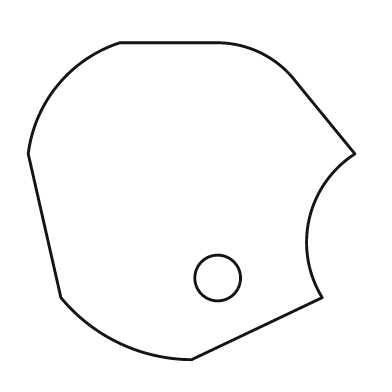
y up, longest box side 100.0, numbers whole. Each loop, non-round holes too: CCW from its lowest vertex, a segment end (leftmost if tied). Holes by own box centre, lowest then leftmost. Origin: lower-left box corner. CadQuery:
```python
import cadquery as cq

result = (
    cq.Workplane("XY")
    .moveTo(50.0, 0.0)
    .lineTo(90.0, 19.0)
    .threePointArc((86.0, 43.0), (100.0, 63.0))
    .lineTo(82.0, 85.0)
    .threePointArc((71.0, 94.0), (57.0, 97.0))
    .lineTo(28.0, 97.0)
    .threePointArc((9.0, 84.0), (0.0, 63.0))
    .lineTo(10.0, 19.0)
    .threePointArc((28.0, 5.0), (50.0, 0.0))
    .close()
    .moveTo(58.0, 25.0)
    .circle(7.0)
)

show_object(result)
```